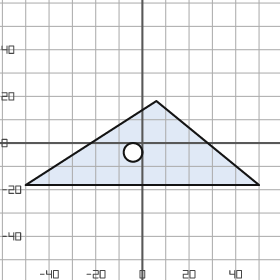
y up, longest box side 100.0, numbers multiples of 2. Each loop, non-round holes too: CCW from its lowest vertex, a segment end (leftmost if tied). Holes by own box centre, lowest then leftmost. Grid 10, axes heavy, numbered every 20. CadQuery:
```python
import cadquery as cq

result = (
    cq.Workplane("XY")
    .moveTo(-50.0, -18.0)
    .lineTo(50.0, -18.0)
    .lineTo(6.0, 18.0)
    .close()
    .moveTo(-4.0, -4.0)
    .circle(4.0)
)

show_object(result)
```